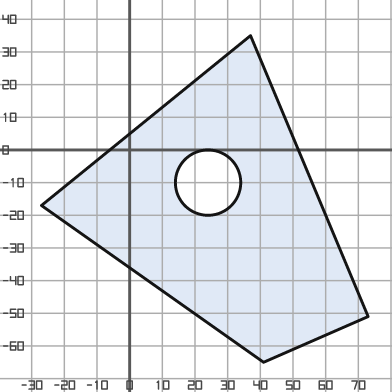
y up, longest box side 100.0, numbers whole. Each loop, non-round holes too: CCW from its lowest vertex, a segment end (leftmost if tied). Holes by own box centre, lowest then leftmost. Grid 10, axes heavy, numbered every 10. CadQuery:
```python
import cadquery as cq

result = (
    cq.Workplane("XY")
    .moveTo(41.0, -65.0)
    .lineTo(73.0, -51.0)
    .lineTo(37.0, 35.0)
    .lineTo(-27.0, -17.0)
    .close()
    .moveTo(24.0, -10.0)
    .circle(10.0)
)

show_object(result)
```